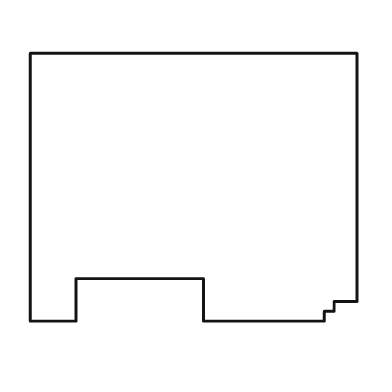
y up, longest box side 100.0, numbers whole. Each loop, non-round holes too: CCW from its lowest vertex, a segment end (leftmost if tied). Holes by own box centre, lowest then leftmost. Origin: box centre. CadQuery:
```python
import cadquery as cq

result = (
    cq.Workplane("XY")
    .moveTo(-50.0, -41.0)
    .lineTo(-36.0, -41.0)
    .lineTo(-36.0, -28.0)
    .lineTo(3.0, -28.0)
    .lineTo(3.0, -41.0)
    .lineTo(40.0, -41.0)
    .lineTo(40.0, -38.0)
    .lineTo(43.0, -38.0)
    .lineTo(43.0, -35.0)
    .lineTo(50.0, -35.0)
    .lineTo(50.0, 41.0)
    .lineTo(-50.0, 41.0)
    .close()
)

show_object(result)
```